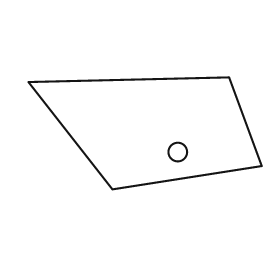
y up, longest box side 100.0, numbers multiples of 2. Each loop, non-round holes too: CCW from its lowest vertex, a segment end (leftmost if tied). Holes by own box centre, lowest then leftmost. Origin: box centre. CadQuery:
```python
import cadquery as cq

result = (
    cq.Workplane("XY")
    .moveTo(-14.0, -24.0)
    .lineTo(50.0, -14.0)
    .lineTo(36.0, 24.0)
    .lineTo(-50.0, 22.0)
    .close()
    .moveTo(14.0, -8.0)
    .circle(4.0)
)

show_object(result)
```